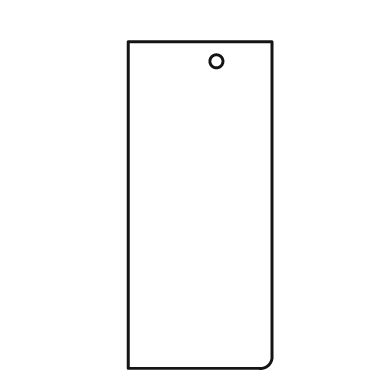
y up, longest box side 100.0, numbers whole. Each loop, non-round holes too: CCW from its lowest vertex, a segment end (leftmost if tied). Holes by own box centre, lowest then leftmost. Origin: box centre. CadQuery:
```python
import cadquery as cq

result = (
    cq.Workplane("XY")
    .moveTo(-22.0, -50.0)
    .lineTo(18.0, -50.0)
    .threePointArc((21.0, -49.0), (22.0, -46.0))
    .lineTo(22.0, 50.0)
    .lineTo(-22.0, 50.0)
    .close()
    .moveTo(5.0, 44.0)
    .circle(2.0)
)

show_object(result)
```